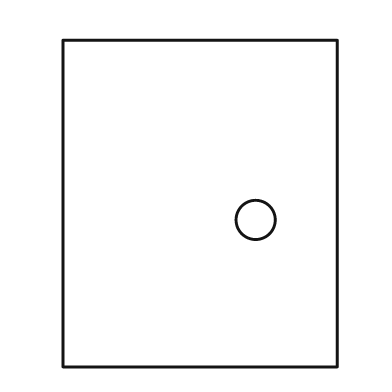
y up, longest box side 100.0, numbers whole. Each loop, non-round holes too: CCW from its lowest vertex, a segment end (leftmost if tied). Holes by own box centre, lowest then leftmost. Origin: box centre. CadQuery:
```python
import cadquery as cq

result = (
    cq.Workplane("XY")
    .moveTo(-42.0, -50.0)
    .lineTo(42.0, -50.0)
    .lineTo(42.0, 50.0)
    .lineTo(-42.0, 50.0)
    .close()
    .moveTo(17.0, -5.0)
    .circle(6.0)
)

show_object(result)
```